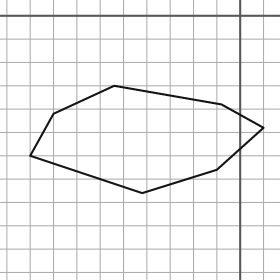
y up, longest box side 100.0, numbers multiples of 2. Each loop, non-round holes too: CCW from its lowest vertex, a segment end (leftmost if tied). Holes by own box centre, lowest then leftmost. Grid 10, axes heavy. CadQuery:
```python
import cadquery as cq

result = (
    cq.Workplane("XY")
    .moveTo(-42.0, -76.0)
    .lineTo(-10.0, -66.0)
    .lineTo(10.0, -48.0)
    .lineTo(-8.0, -38.0)
    .lineTo(-54.0, -30.0)
    .lineTo(-80.0, -42.0)
    .lineTo(-90.0, -60.0)
    .close()
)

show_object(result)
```